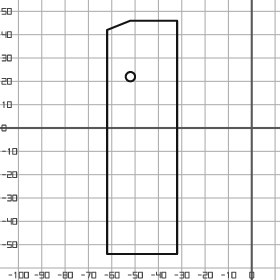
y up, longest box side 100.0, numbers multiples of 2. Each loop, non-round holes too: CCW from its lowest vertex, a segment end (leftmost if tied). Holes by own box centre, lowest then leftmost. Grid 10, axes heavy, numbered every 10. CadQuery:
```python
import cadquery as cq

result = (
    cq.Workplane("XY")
    .moveTo(-62.0, -54.0)
    .lineTo(-32.0, -54.0)
    .lineTo(-32.0, 46.0)
    .lineTo(-52.0, 46.0)
    .lineTo(-62.0, 42.0)
    .close()
    .moveTo(-52.0, 22.0)
    .circle(2.0)
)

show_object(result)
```